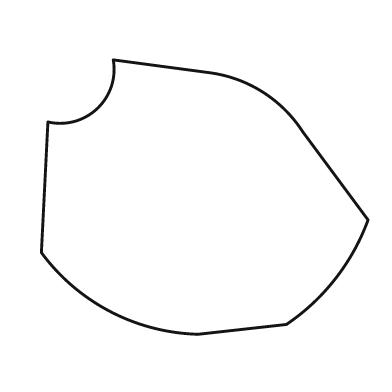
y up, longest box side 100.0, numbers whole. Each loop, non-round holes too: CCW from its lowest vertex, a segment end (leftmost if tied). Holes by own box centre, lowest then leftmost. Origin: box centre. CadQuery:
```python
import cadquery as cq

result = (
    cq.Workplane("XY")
    .moveTo(-2.0, -42.0)
    .lineTo(25.0, -39.0)
    .threePointArc((40.0, -25.0), (50.0, -7.0))
    .lineTo(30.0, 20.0)
    .threePointArc((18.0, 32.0), (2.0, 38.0))
    .lineTo(-28.0, 42.0)
    .threePointArc((-33.0, 27.0), (-48.0, 23.0))
    .lineTo(-50.0, -17.0)
    .threePointArc((-29.0, -35.0), (-2.0, -42.0))
    .close()
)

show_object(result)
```